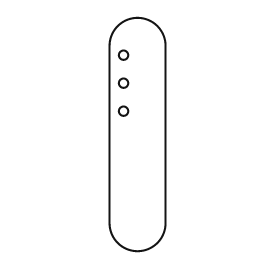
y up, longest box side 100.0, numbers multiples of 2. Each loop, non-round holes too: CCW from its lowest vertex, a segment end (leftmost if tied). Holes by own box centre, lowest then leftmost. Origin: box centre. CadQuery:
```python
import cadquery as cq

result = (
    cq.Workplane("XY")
    .moveTo(-12.0, -38.0)
    .threePointArc((0.0, -50.0), (12.0, -38.0))
    .lineTo(12.0, 38.0)
    .threePointArc((0.0, 50.0), (-12.0, 38.0))
    .close()
    .moveTo(-6.0, 10.0)
    .circle(2.0)
    .moveTo(-6.0, 22.0)
    .circle(2.0)
    .moveTo(-6.0, 34.0)
    .circle(2.0)
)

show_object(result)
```